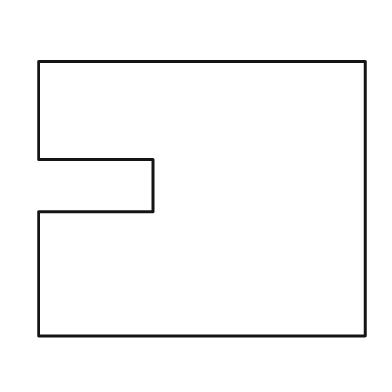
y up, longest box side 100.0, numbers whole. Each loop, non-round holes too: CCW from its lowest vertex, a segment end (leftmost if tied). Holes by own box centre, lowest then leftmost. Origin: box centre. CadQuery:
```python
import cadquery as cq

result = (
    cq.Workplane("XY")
    .moveTo(-50.0, -42.0)
    .lineTo(50.0, -42.0)
    .lineTo(50.0, 42.0)
    .lineTo(-50.0, 42.0)
    .lineTo(-50.0, 12.0)
    .lineTo(-15.0, 12.0)
    .lineTo(-15.0, -4.0)
    .lineTo(-50.0, -4.0)
    .close()
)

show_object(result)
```